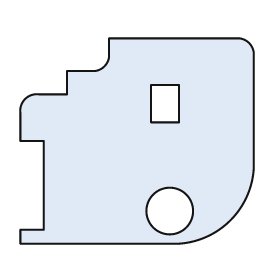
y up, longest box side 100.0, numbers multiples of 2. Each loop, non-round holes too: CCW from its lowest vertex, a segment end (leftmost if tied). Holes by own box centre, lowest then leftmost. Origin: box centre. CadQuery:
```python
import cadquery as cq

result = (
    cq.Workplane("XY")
    .moveTo(-50.0, -44.0)
    .lineTo(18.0, -44.0)
    .threePointArc((40.0, -34.0), (50.0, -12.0))
    .lineTo(50.0, 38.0)
    .threePointArc((48.0, 42.0), (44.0, 44.0))
    .lineTo(-12.0, 44.0)
    .lineTo(-12.0, 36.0)
    .threePointArc((-14.0, 32.0), (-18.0, 30.0))
    .lineTo(-30.0, 30.0)
    .lineTo(-30.0, 20.0)
    .lineTo(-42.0, 20.0)
    .threePointArc((-48.0, 18.0), (-50.0, 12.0))
    .lineTo(-50.0, 0.0)
    .lineTo(-40.0, 0.0)
    .lineTo(-40.0, -38.0)
    .lineTo(-50.0, -38.0)
    .close()
    .moveTo(14.0, -30.0)
    .circle(10.0)
    .moveTo(6.0, 8.0)
    .lineTo(18.0, 8.0)
    .lineTo(18.0, 24.0)
    .lineTo(6.0, 24.0)
    .close()
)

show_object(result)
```